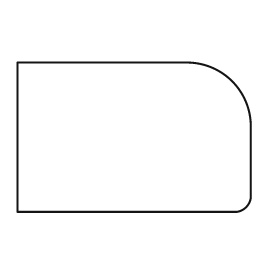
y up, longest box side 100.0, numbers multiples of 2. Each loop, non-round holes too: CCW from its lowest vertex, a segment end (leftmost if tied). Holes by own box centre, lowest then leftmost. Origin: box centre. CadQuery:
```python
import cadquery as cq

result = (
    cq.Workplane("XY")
    .moveTo(-50.0, -32.0)
    .lineTo(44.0, -32.0)
    .threePointArc((48.0, -30.0), (50.0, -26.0))
    .lineTo(50.0, 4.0)
    .threePointArc((42.0, 24.0), (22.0, 32.0))
    .lineTo(-50.0, 32.0)
    .close()
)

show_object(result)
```